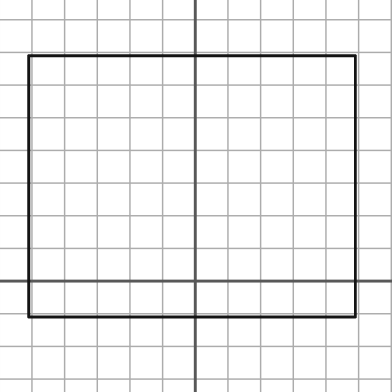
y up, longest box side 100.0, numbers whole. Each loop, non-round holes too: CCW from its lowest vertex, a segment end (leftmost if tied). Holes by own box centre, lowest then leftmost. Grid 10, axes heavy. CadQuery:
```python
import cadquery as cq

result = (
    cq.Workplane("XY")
    .moveTo(-51.0, -11.0)
    .lineTo(49.0, -11.0)
    .lineTo(49.0, 69.0)
    .lineTo(-51.0, 69.0)
    .close()
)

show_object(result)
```